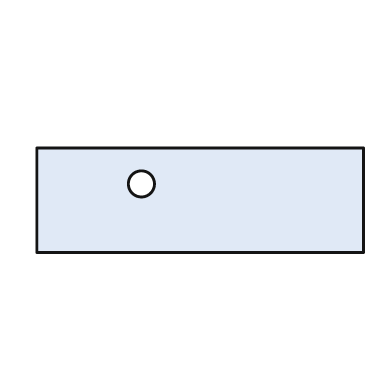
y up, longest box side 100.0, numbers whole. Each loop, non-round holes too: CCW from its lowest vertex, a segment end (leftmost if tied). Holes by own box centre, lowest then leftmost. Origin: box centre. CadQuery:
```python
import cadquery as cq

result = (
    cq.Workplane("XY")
    .moveTo(-50.0, -16.0)
    .lineTo(50.0, -16.0)
    .lineTo(50.0, 16.0)
    .lineTo(-50.0, 16.0)
    .close()
    .moveTo(-18.0, 5.0)
    .circle(4.0)
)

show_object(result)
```